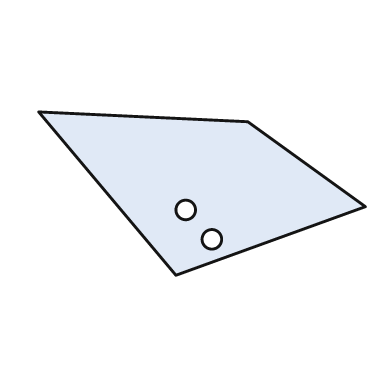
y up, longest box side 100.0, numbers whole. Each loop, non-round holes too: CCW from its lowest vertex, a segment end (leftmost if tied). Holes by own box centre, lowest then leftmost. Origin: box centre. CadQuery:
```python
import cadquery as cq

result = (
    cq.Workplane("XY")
    .moveTo(-8.0, -25.0)
    .lineTo(50.0, -4.0)
    .lineTo(14.0, 22.0)
    .lineTo(-50.0, 25.0)
    .close()
    .moveTo(3.0, -14.0)
    .circle(3.0)
    .moveTo(-5.0, -5.0)
    .circle(3.0)
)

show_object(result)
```